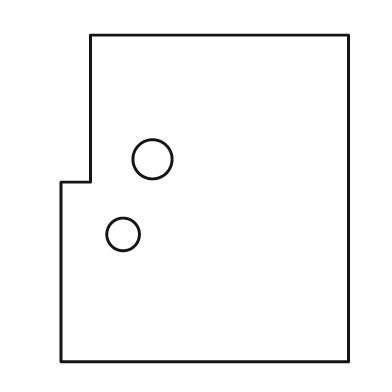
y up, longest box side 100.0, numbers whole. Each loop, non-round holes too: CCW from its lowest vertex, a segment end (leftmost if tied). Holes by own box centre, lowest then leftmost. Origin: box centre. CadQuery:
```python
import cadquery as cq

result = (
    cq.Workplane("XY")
    .moveTo(-44.0, -50.0)
    .lineTo(44.0, -50.0)
    .lineTo(44.0, 50.0)
    .lineTo(-35.0, 50.0)
    .lineTo(-35.0, 5.0)
    .lineTo(-44.0, 5.0)
    .close()
    .moveTo(-25.0, -11.0)
    .circle(5.0)
    .moveTo(-16.0, 12.0)
    .circle(6.0)
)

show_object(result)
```